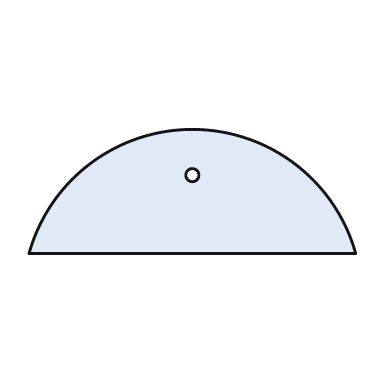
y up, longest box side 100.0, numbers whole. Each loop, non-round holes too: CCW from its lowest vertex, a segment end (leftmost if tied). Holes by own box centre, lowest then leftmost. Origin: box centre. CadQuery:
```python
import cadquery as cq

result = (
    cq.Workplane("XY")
    .moveTo(-50.0, -19.0)
    .lineTo(50.0, -19.0)
    .threePointArc((0.0, 19.0), (-50.0, -19.0))
    .close()
    .moveTo(0.0, 5.0)
    .circle(2.0)
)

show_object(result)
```